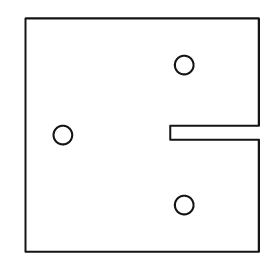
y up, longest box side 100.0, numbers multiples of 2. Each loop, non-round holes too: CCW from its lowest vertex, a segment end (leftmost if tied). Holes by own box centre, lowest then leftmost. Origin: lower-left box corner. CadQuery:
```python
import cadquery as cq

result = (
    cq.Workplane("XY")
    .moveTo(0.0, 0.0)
    .lineTo(100.0, 0.0)
    .lineTo(100.0, 48.0)
    .lineTo(62.0, 48.0)
    .lineTo(62.0, 54.0)
    .lineTo(100.0, 54.0)
    .lineTo(100.0, 100.0)
    .lineTo(0.0, 100.0)
    .close()
    .moveTo(68.0, 20.0)
    .circle(4.0)
    .moveTo(16.0, 50.0)
    .circle(4.0)
    .moveTo(68.0, 80.0)
    .circle(4.0)
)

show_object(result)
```